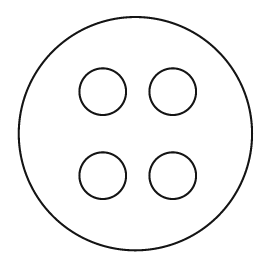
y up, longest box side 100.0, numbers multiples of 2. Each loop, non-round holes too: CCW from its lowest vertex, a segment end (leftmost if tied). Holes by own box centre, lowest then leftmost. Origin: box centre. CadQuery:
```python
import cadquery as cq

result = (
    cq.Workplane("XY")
    .moveTo(0.0, 0.0)
    .circle(50.0)
    .moveTo(-14.0, -18.0)
    .circle(10.0)
    .moveTo(16.0, -18.0)
    .circle(10.0)
    .moveTo(-14.0, 18.0)
    .circle(10.0)
    .moveTo(16.0, 18.0)
    .circle(10.0)
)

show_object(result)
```